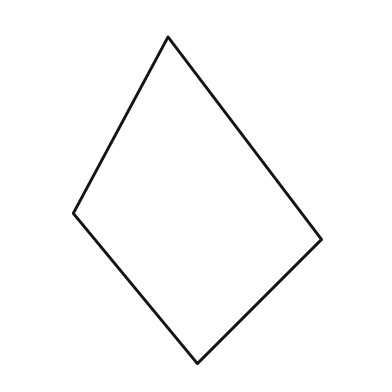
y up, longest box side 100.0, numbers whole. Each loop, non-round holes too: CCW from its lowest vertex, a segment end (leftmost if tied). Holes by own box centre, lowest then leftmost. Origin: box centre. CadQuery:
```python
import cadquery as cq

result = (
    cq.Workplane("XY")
    .moveTo(0.0, -50.0)
    .lineTo(38.0, -12.0)
    .lineTo(-9.0, 50.0)
    .lineTo(-38.0, -4.0)
    .close()
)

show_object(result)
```